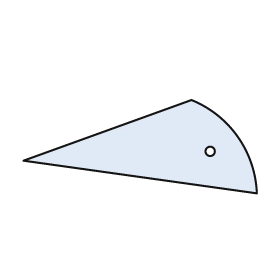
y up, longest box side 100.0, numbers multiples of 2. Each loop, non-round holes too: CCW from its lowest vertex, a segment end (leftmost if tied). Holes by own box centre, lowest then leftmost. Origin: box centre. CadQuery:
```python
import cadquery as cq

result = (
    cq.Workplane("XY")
    .moveTo(50.0, -20.0)
    .threePointArc((42.0, 4.0), (22.0, 20.0))
    .lineTo(-50.0, -6.0)
    .close()
    .moveTo(30.0, -2.0)
    .circle(2.0)
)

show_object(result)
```